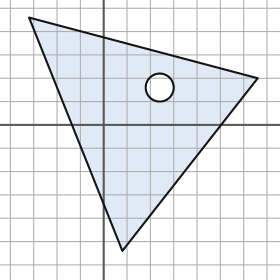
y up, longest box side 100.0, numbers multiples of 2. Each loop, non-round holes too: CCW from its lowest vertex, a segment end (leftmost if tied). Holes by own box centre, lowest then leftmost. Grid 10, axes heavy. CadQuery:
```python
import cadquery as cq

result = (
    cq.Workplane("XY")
    .moveTo(8.0, -54.0)
    .lineTo(66.0, 20.0)
    .lineTo(-32.0, 46.0)
    .close()
    .moveTo(24.0, 16.0)
    .circle(6.0)
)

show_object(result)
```